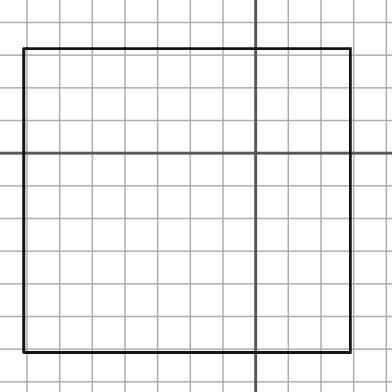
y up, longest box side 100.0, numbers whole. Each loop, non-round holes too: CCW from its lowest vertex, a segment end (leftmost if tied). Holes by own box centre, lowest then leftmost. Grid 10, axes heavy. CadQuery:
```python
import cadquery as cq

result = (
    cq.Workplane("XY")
    .moveTo(-71.0, -61.0)
    .lineTo(29.0, -61.0)
    .lineTo(29.0, 32.0)
    .lineTo(-71.0, 32.0)
    .close()
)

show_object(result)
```